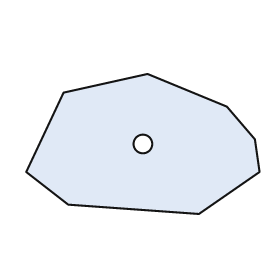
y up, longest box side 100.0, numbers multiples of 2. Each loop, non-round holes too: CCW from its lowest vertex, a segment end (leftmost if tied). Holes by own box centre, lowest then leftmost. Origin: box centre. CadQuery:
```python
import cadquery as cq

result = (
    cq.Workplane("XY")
    .moveTo(24.0, -30.0)
    .lineTo(50.0, -12.0)
    .lineTo(48.0, 2.0)
    .lineTo(36.0, 16.0)
    .lineTo(2.0, 30.0)
    .lineTo(-34.0, 22.0)
    .lineTo(-50.0, -12.0)
    .lineTo(-32.0, -26.0)
    .close()
    .moveTo(0.0, 0.0)
    .circle(4.0)
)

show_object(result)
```